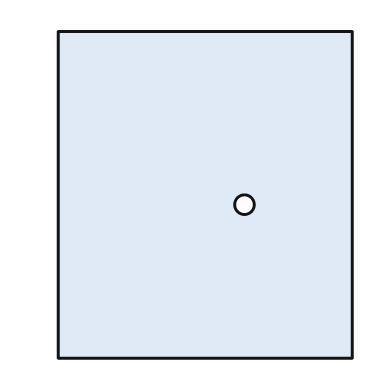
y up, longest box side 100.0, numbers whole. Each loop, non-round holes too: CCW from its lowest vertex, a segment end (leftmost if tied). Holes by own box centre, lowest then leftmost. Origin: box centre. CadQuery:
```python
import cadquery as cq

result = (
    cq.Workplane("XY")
    .moveTo(-45.0, -50.0)
    .lineTo(45.0, -50.0)
    .lineTo(45.0, 50.0)
    .lineTo(-45.0, 50.0)
    .close()
    .moveTo(12.0, -3.0)
    .circle(3.0)
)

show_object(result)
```